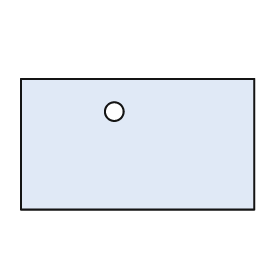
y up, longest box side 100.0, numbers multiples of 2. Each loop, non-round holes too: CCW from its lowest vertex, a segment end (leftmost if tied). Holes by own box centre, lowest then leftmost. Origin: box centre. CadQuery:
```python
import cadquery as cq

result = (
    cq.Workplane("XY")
    .moveTo(-50.0, -28.0)
    .lineTo(50.0, -28.0)
    .lineTo(50.0, 28.0)
    .lineTo(-50.0, 28.0)
    .close()
    .moveTo(-10.0, 14.0)
    .circle(4.0)
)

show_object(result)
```